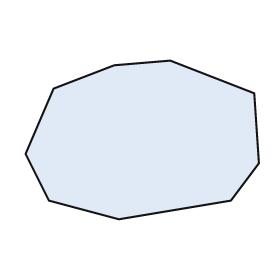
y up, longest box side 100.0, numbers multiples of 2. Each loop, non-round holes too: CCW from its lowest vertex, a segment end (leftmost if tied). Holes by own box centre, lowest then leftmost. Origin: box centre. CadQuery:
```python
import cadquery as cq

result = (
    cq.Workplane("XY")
    .moveTo(-10.0, -34.0)
    .lineTo(38.0, -26.0)
    .lineTo(50.0, -10.0)
    .lineTo(48.0, 20.0)
    .lineTo(12.0, 34.0)
    .lineTo(-12.0, 32.0)
    .lineTo(-38.0, 22.0)
    .lineTo(-50.0, -6.0)
    .lineTo(-40.0, -26.0)
    .close()
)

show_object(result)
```